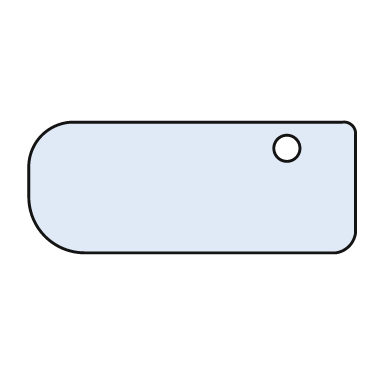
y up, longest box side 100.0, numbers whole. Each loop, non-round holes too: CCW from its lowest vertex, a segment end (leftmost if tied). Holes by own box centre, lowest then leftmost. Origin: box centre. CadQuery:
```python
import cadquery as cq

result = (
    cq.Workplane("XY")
    .moveTo(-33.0, -20.0)
    .lineTo(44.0, -20.0)
    .threePointArc((48.0, -18.0), (50.0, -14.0))
    .lineTo(50.0, 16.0)
    .threePointArc((49.0, 19.0), (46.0, 20.0))
    .lineTo(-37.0, 20.0)
    .threePointArc((-46.0, 16.0), (-50.0, 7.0))
    .lineTo(-50.0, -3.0)
    .threePointArc((-45.0, -15.0), (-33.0, -20.0))
    .close()
    .moveTo(29.0, 12.0)
    .circle(4.0)
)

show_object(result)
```